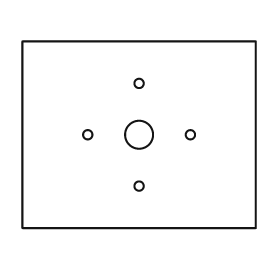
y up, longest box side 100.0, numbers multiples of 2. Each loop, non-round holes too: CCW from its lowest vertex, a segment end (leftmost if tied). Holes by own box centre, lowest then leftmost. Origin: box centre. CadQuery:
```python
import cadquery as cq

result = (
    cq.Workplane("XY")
    .moveTo(-50.0, -40.0)
    .lineTo(50.0, -40.0)
    .lineTo(50.0, 40.0)
    .lineTo(-50.0, 40.0)
    .close()
    .moveTo(0.0, -22.0)
    .circle(2.0)
    .moveTo(-22.0, 0.0)
    .circle(2.0)
    .moveTo(0.0, 0.0)
    .circle(6.0)
    .moveTo(22.0, 0.0)
    .circle(2.0)
    .moveTo(0.0, 22.0)
    .circle(2.0)
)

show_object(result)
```